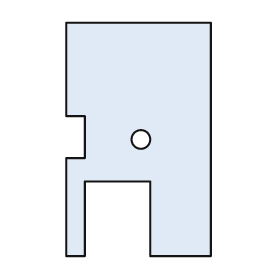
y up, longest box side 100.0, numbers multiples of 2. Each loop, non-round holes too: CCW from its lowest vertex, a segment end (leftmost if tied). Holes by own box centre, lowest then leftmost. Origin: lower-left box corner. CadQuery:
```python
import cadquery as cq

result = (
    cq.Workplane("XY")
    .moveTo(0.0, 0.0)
    .lineTo(8.0, 0.0)
    .lineTo(8.0, 32.0)
    .lineTo(36.0, 32.0)
    .lineTo(36.0, 0.0)
    .lineTo(62.0, 0.0)
    .lineTo(62.0, 100.0)
    .lineTo(0.0, 100.0)
    .lineTo(0.0, 60.0)
    .lineTo(8.0, 60.0)
    .lineTo(8.0, 42.0)
    .lineTo(0.0, 42.0)
    .close()
    .moveTo(32.0, 50.0)
    .circle(4.0)
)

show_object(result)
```